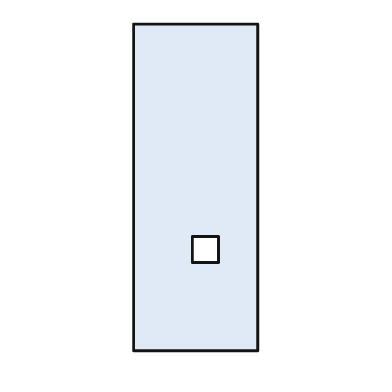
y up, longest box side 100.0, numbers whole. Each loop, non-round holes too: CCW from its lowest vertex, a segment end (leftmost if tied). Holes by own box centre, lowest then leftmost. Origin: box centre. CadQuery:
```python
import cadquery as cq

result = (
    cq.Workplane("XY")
    .moveTo(-19.0, -50.0)
    .lineTo(19.0, -50.0)
    .lineTo(19.0, 50.0)
    .lineTo(-19.0, 50.0)
    .close()
    .moveTo(-1.0, -23.0)
    .lineTo(7.0, -23.0)
    .lineTo(7.0, -15.0)
    .lineTo(-1.0, -15.0)
    .close()
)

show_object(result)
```